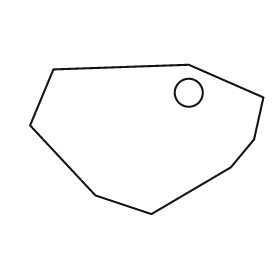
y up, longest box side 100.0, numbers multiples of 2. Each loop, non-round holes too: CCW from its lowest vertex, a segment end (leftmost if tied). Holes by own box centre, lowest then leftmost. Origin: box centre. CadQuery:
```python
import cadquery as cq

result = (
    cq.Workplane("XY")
    .moveTo(2.0, -32.0)
    .lineTo(36.0, -12.0)
    .lineTo(46.0, 0.0)
    .lineTo(50.0, 18.0)
    .lineTo(18.0, 32.0)
    .lineTo(-40.0, 30.0)
    .lineTo(-50.0, 6.0)
    .lineTo(-22.0, -24.0)
    .close()
    .moveTo(18.0, 20.0)
    .circle(6.0)
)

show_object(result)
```